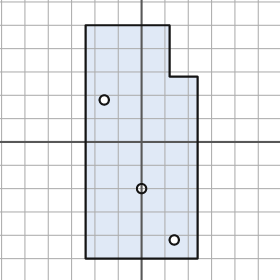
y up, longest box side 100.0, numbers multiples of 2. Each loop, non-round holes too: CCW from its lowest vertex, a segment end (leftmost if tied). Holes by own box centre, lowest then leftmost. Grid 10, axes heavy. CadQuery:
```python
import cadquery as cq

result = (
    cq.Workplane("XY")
    .moveTo(-24.0, -50.0)
    .lineTo(24.0, -50.0)
    .lineTo(24.0, 28.0)
    .lineTo(12.0, 28.0)
    .lineTo(12.0, 50.0)
    .lineTo(-24.0, 50.0)
    .close()
    .moveTo(14.0, -42.0)
    .circle(2.0)
    .moveTo(0.0, -20.0)
    .circle(2.0)
    .moveTo(-16.0, 18.0)
    .circle(2.0)
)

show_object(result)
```